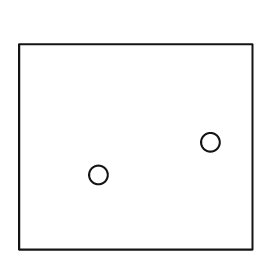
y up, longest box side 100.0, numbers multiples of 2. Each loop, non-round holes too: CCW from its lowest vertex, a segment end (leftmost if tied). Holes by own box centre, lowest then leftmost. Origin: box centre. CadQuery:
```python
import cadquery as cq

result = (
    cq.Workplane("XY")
    .moveTo(-50.0, -44.0)
    .lineTo(50.0, -44.0)
    .lineTo(50.0, 44.0)
    .lineTo(-50.0, 44.0)
    .close()
    .moveTo(-16.0, -12.0)
    .circle(4.0)
    .moveTo(32.0, 2.0)
    .circle(4.0)
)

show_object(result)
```